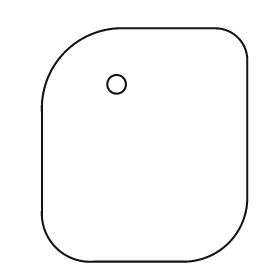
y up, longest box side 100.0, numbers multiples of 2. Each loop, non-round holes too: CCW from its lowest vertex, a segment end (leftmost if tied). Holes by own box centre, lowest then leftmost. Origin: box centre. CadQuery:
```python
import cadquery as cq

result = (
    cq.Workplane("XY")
    .moveTo(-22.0, -50.0)
    .lineTo(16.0, -50.0)
    .threePointArc((36.0, -42.0), (44.0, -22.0))
    .lineTo(44.0, 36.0)
    .threePointArc((40.0, 46.0), (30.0, 50.0))
    .lineTo(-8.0, 50.0)
    .threePointArc((-34.0, 40.0), (-44.0, 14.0))
    .lineTo(-44.0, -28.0)
    .threePointArc((-38.0, -44.0), (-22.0, -50.0))
    .close()
    .moveTo(-12.0, 26.0)
    .circle(4.0)
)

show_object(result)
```